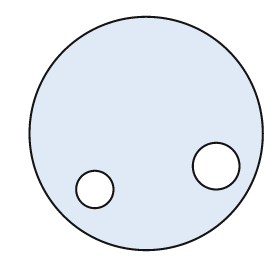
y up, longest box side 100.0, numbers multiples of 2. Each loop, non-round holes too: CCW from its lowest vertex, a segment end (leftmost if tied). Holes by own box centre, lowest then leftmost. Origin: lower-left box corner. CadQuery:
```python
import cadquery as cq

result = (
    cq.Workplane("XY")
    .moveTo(50.0, 50.0)
    .circle(50.0)
    .moveTo(28.0, 26.0)
    .circle(8.0)
    .moveTo(80.0, 36.0)
    .circle(10.0)
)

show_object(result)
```